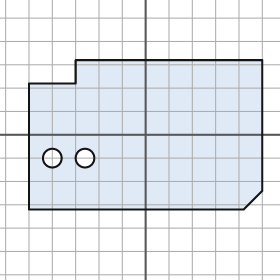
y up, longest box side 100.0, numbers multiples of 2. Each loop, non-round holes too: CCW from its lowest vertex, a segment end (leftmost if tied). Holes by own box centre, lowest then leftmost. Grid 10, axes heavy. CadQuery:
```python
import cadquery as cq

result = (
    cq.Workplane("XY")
    .moveTo(-50.0, -32.0)
    .lineTo(42.0, -32.0)
    .lineTo(50.0, -24.0)
    .lineTo(50.0, 32.0)
    .lineTo(-30.0, 32.0)
    .lineTo(-30.0, 22.0)
    .lineTo(-50.0, 22.0)
    .close()
    .moveTo(-40.0, -10.0)
    .circle(4.0)
    .moveTo(-26.0, -10.0)
    .circle(4.0)
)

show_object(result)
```